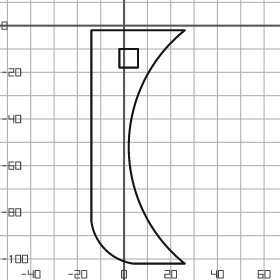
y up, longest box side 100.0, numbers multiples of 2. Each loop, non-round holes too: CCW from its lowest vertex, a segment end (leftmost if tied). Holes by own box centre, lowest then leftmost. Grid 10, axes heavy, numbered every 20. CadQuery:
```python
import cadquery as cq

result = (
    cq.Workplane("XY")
    .moveTo(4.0, -102.0)
    .lineTo(26.0, -102.0)
    .threePointArc((2.0, -52.0), (26.0, -2.0))
    .lineTo(-14.0, -2.0)
    .lineTo(-14.0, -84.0)
    .threePointArc((-8.0, -96.0), (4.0, -102.0))
    .close()
    .moveTo(-2.0, -18.0)
    .lineTo(6.0, -18.0)
    .lineTo(6.0, -10.0)
    .lineTo(-2.0, -10.0)
    .close()
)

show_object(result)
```